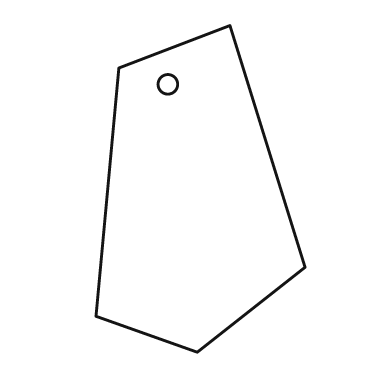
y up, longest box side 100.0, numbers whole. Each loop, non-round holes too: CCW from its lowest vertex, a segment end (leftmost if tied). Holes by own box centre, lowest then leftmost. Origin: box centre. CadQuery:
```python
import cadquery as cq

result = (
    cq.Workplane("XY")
    .moveTo(-1.0, -50.0)
    .lineTo(32.0, -24.0)
    .lineTo(9.0, 50.0)
    .lineTo(-25.0, 37.0)
    .lineTo(-32.0, -39.0)
    .close()
    .moveTo(-10.0, 32.0)
    .circle(3.0)
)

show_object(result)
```